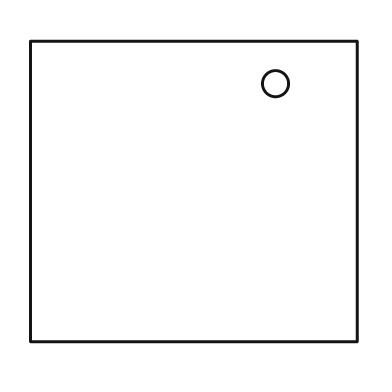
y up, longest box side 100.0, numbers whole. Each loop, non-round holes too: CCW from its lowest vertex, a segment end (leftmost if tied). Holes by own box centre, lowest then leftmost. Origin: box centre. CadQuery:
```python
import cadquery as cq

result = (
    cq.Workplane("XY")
    .moveTo(-50.0, -46.0)
    .lineTo(50.0, -46.0)
    .lineTo(50.0, 46.0)
    .lineTo(-50.0, 46.0)
    .close()
    .moveTo(25.0, 33.0)
    .circle(4.0)
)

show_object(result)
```